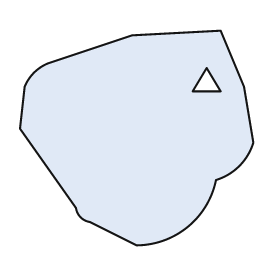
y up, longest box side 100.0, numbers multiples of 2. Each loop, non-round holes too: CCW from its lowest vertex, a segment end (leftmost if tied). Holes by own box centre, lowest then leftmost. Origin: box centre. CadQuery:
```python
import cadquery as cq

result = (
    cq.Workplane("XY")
    .moveTo(0.0, -46.0)
    .threePointArc((22.0, -38.0), (34.0, -18.0))
    .threePointArc((44.0, -12.0), (50.0, -2.0))
    .lineTo(46.0, 22.0)
    .lineTo(36.0, 46.0)
    .lineTo(-2.0, 44.0)
    .lineTo(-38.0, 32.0)
    .threePointArc((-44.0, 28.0), (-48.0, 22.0))
    .lineTo(-50.0, 4.0)
    .lineTo(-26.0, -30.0)
    .threePointArc((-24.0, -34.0), (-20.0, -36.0))
    .close()
    .moveTo(24.0, 20.0)
    .lineTo(36.0, 20.0)
    .lineTo(30.0, 30.0)
    .close()
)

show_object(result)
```